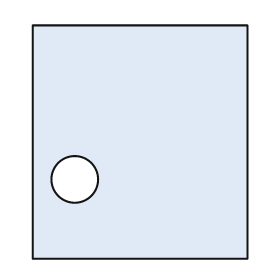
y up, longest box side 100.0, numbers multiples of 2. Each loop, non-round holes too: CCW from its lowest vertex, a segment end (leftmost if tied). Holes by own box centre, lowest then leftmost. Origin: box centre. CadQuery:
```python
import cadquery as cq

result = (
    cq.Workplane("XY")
    .moveTo(-46.0, -50.0)
    .lineTo(46.0, -50.0)
    .lineTo(46.0, 50.0)
    .lineTo(-46.0, 50.0)
    .close()
    .moveTo(-28.0, -16.0)
    .circle(10.0)
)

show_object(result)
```